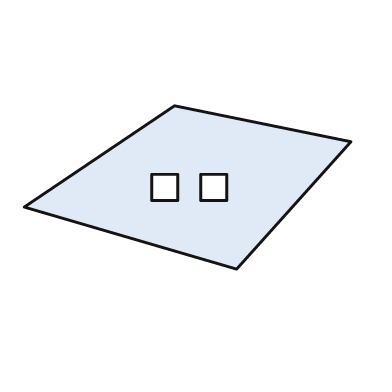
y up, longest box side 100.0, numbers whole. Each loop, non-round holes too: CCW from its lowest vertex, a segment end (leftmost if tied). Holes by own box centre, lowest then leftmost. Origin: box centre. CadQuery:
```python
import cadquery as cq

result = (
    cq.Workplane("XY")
    .moveTo(15.0, -25.0)
    .lineTo(50.0, 14.0)
    .lineTo(-4.0, 25.0)
    .lineTo(-50.0, -6.0)
    .close()
    .moveTo(-11.0, -4.0)
    .lineTo(-3.0, -4.0)
    .lineTo(-3.0, 4.0)
    .lineTo(-11.0, 4.0)
    .close()
    .moveTo(4.0, -4.0)
    .lineTo(12.0, -4.0)
    .lineTo(12.0, 4.0)
    .lineTo(4.0, 4.0)
    .close()
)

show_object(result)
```